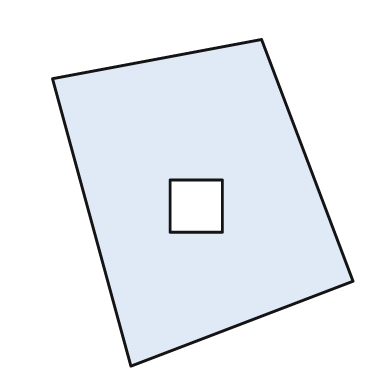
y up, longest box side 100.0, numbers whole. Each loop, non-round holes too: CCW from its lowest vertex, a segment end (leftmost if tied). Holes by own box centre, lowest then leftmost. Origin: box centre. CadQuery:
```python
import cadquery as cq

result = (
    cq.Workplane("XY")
    .moveTo(-22.0, -50.0)
    .lineTo(46.0, -24.0)
    .lineTo(18.0, 50.0)
    .lineTo(-46.0, 38.0)
    .close()
    .moveTo(-10.0, -9.0)
    .lineTo(6.0, -9.0)
    .lineTo(6.0, 7.0)
    .lineTo(-10.0, 7.0)
    .close()
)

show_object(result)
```